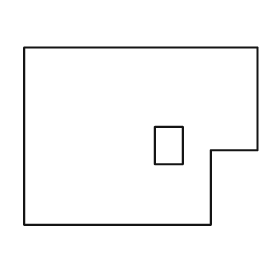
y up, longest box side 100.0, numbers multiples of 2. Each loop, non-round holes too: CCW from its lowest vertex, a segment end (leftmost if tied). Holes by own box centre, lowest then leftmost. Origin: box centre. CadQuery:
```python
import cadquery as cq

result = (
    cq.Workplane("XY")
    .moveTo(-50.0, -38.0)
    .lineTo(30.0, -38.0)
    .lineTo(30.0, -6.0)
    .lineTo(50.0, -6.0)
    .lineTo(50.0, 38.0)
    .lineTo(-50.0, 38.0)
    .close()
    .moveTo(6.0, -12.0)
    .lineTo(18.0, -12.0)
    .lineTo(18.0, 4.0)
    .lineTo(6.0, 4.0)
    .close()
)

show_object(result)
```